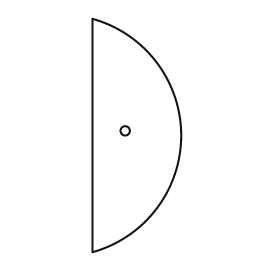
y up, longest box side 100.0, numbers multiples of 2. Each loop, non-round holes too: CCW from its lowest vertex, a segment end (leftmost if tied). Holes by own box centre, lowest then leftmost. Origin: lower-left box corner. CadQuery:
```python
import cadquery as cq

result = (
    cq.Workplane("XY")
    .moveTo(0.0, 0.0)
    .threePointArc((38.0, 50.0), (0.0, 100.0))
    .close()
    .moveTo(14.0, 52.0)
    .circle(2.0)
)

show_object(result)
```